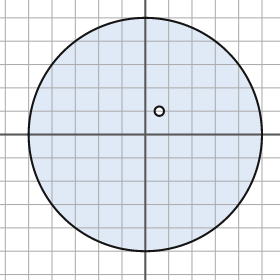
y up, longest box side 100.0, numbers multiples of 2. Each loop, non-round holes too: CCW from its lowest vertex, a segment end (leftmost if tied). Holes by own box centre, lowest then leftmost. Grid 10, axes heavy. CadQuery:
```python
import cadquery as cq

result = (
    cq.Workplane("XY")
    .moveTo(0.0, 0.0)
    .circle(50.0)
    .moveTo(6.0, 10.0)
    .circle(2.0)
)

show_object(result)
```